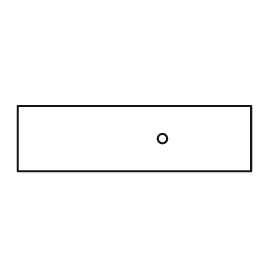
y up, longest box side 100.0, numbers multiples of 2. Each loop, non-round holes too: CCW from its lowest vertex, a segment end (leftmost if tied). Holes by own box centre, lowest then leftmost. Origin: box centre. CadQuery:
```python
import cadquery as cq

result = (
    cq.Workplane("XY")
    .moveTo(-50.0, -14.0)
    .lineTo(50.0, -14.0)
    .lineTo(50.0, 14.0)
    .lineTo(-50.0, 14.0)
    .close()
    .moveTo(12.0, 0.0)
    .circle(2.0)
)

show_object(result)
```